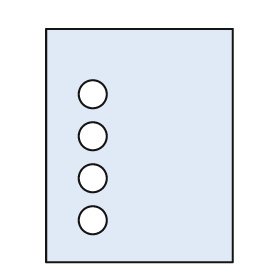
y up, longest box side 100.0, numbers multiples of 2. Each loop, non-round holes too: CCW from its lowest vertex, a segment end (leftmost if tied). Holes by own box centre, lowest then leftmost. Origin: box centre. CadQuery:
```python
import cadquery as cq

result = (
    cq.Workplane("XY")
    .moveTo(-40.0, -50.0)
    .lineTo(40.0, -50.0)
    .lineTo(40.0, 50.0)
    .lineTo(-40.0, 50.0)
    .close()
    .moveTo(-20.0, -32.0)
    .circle(6.0)
    .moveTo(-20.0, -14.0)
    .circle(6.0)
    .moveTo(-20.0, 4.0)
    .circle(6.0)
    .moveTo(-20.0, 22.0)
    .circle(6.0)
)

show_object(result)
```